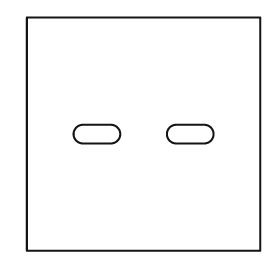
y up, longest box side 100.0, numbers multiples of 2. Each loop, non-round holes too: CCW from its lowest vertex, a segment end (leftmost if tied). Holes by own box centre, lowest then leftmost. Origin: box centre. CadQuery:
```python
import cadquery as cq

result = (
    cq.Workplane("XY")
    .moveTo(-50.0, -50.0)
    .lineTo(50.0, -50.0)
    .lineTo(50.0, 50.0)
    .lineTo(-50.0, 50.0)
    .close()
    .moveTo(-26.0, -4.0)
    .lineTo(-14.0, -4.0)
    .threePointArc((-10.0, 0.0), (-14.0, 4.0))
    .lineTo(-26.0, 4.0)
    .threePointArc((-30.0, 0.0), (-26.0, -4.0))
    .close()
    .moveTo(14.0, -4.0)
    .lineTo(26.0, -4.0)
    .threePointArc((30.0, 0.0), (26.0, 4.0))
    .lineTo(14.0, 4.0)
    .threePointArc((10.0, 0.0), (14.0, -4.0))
    .close()
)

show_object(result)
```